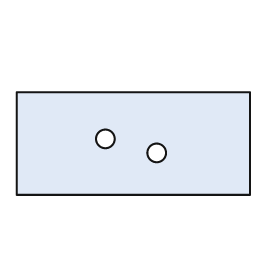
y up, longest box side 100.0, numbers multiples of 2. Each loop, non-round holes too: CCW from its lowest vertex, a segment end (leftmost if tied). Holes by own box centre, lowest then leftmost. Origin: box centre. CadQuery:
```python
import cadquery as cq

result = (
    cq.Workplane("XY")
    .moveTo(-50.0, -22.0)
    .lineTo(50.0, -22.0)
    .lineTo(50.0, 22.0)
    .lineTo(-50.0, 22.0)
    .close()
    .moveTo(10.0, -4.0)
    .circle(4.0)
    .moveTo(-12.0, 2.0)
    .circle(4.0)
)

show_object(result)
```